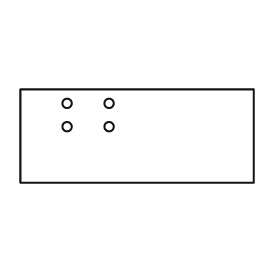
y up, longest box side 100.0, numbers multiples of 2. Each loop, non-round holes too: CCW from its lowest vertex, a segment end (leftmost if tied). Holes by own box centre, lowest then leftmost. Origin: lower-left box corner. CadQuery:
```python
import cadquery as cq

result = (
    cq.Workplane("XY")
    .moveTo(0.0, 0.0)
    .lineTo(100.0, 0.0)
    .lineTo(100.0, 40.0)
    .lineTo(0.0, 40.0)
    .close()
    .moveTo(20.0, 24.0)
    .circle(2.0)
    .moveTo(38.0, 24.0)
    .circle(2.0)
    .moveTo(20.0, 34.0)
    .circle(2.0)
    .moveTo(38.0, 34.0)
    .circle(2.0)
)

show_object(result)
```